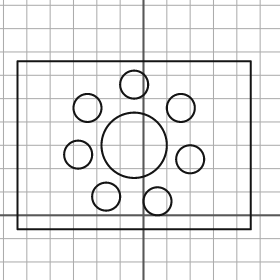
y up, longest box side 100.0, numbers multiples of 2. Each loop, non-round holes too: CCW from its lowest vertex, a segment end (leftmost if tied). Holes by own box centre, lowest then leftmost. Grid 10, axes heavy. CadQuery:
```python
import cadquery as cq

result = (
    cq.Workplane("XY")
    .moveTo(-54.0, -6.0)
    .lineTo(46.0, -6.0)
    .lineTo(46.0, 66.0)
    .lineTo(-54.0, 66.0)
    .close()
    .moveTo(6.0, 6.0)
    .circle(6.0)
    .moveTo(-16.0, 8.0)
    .circle(6.0)
    .moveTo(20.0, 24.0)
    .circle(6.0)
    .moveTo(-28.0, 26.0)
    .circle(6.0)
    .moveTo(-4.0, 30.0)
    .circle(14.0)
    .moveTo(-24.0, 46.0)
    .circle(6.0)
    .moveTo(16.0, 46.0)
    .circle(6.0)
    .moveTo(-4.0, 56.0)
    .circle(6.0)
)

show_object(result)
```